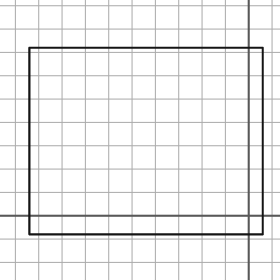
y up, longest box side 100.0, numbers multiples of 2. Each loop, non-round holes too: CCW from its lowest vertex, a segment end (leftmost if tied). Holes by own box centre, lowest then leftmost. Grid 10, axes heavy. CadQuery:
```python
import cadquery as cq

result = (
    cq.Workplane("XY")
    .moveTo(-94.0, -8.0)
    .lineTo(6.0, -8.0)
    .lineTo(6.0, 72.0)
    .lineTo(-94.0, 72.0)
    .close()
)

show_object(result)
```